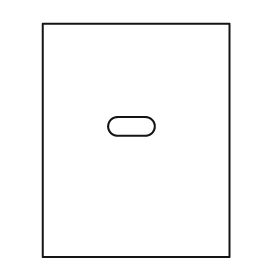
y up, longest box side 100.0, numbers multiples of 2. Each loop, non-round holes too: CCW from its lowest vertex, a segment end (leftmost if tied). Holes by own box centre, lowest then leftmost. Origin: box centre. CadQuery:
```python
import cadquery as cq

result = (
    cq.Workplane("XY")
    .moveTo(-40.0, -50.0)
    .lineTo(40.0, -50.0)
    .lineTo(40.0, 50.0)
    .lineTo(-40.0, 50.0)
    .close()
    .moveTo(-8.0, 2.0)
    .lineTo(4.0, 2.0)
    .threePointArc((8.0, 6.0), (4.0, 10.0))
    .lineTo(-8.0, 10.0)
    .threePointArc((-12.0, 6.0), (-8.0, 2.0))
    .close()
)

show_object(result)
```